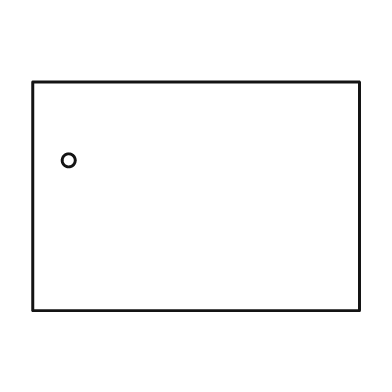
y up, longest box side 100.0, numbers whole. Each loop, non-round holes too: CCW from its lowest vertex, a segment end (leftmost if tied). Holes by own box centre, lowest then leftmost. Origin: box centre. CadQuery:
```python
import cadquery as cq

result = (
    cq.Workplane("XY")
    .moveTo(-50.0, -35.0)
    .lineTo(50.0, -35.0)
    .lineTo(50.0, 35.0)
    .lineTo(-50.0, 35.0)
    .close()
    .moveTo(-39.0, 11.0)
    .circle(2.0)
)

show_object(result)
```